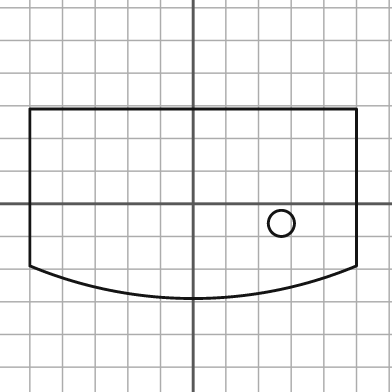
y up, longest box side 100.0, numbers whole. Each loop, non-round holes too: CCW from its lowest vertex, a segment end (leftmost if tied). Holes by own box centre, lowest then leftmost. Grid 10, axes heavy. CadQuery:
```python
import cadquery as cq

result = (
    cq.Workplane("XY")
    .moveTo(-50.0, -19.0)
    .threePointArc((0.0, -29.0), (50.0, -19.0))
    .lineTo(50.0, 29.0)
    .lineTo(-50.0, 29.0)
    .close()
    .moveTo(27.0, -6.0)
    .circle(4.0)
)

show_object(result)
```